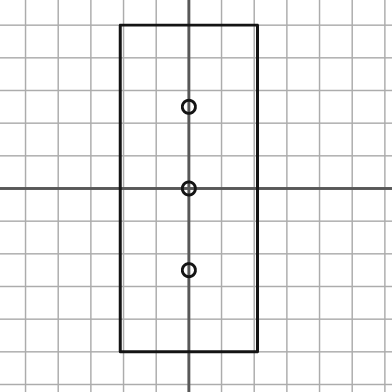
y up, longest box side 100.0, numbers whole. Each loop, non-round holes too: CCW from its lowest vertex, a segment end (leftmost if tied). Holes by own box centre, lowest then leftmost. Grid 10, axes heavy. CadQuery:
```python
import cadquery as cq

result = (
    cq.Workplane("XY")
    .moveTo(-21.0, -50.0)
    .lineTo(21.0, -50.0)
    .lineTo(21.0, 50.0)
    .lineTo(-21.0, 50.0)
    .close()
    .moveTo(0.0, -25.0)
    .circle(2.0)
    .moveTo(0.0, 0.0)
    .circle(2.0)
    .moveTo(0.0, 25.0)
    .circle(2.0)
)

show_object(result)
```